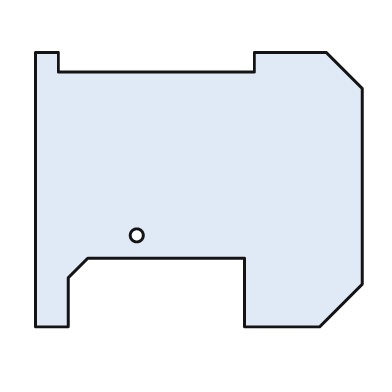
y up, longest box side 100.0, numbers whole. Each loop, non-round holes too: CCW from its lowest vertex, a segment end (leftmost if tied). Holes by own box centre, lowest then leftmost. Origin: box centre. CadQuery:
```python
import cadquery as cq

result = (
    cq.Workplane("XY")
    .moveTo(-50.0, -42.0)
    .lineTo(-40.0, -42.0)
    .lineTo(-40.0, -27.0)
    .lineTo(-34.0, -21.0)
    .lineTo(14.0, -21.0)
    .lineTo(14.0, -42.0)
    .lineTo(37.0, -42.0)
    .lineTo(50.0, -29.0)
    .lineTo(50.0, 31.0)
    .lineTo(39.0, 42.0)
    .lineTo(17.0, 42.0)
    .lineTo(17.0, 36.0)
    .lineTo(-43.0, 36.0)
    .lineTo(-43.0, 42.0)
    .lineTo(-50.0, 42.0)
    .close()
    .moveTo(-19.0, -14.0)
    .circle(2.0)
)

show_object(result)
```